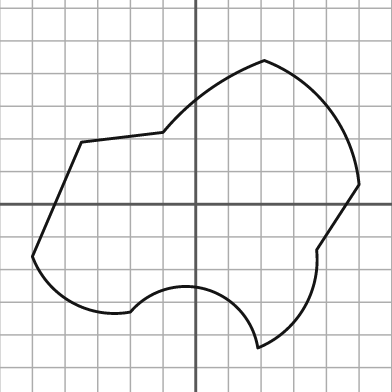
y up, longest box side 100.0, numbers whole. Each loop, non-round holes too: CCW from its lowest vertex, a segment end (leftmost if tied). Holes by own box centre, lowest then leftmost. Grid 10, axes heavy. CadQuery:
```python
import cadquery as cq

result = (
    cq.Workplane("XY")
    .moveTo(19.0, -44.0)
    .threePointArc((33.0, -32.0), (37.0, -14.0))
    .lineTo(50.0, 6.0)
    .threePointArc((41.0, 29.0), (21.0, 44.0))
    .threePointArc((4.0, 35.0), (-10.0, 22.0))
    .lineTo(-35.0, 19.0)
    .lineTo(-50.0, -16.0)
    .threePointArc((-38.0, -30.0), (-20.0, -33.0))
    .threePointArc((3.0, -26.0), (19.0, -44.0))
    .close()
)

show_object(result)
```